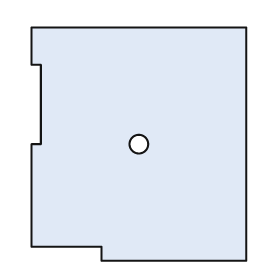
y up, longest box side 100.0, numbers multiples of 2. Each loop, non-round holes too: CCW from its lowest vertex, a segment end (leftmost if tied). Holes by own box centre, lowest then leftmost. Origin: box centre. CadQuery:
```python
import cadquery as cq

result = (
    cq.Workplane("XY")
    .moveTo(-16.0, -50.0)
    .lineTo(46.0, -50.0)
    .lineTo(46.0, 50.0)
    .lineTo(-46.0, 50.0)
    .lineTo(-46.0, 34.0)
    .lineTo(-42.0, 34.0)
    .lineTo(-42.0, 0.0)
    .lineTo(-46.0, 0.0)
    .lineTo(-46.0, -44.0)
    .lineTo(-16.0, -44.0)
    .close()
    .moveTo(0.0, 0.0)
    .circle(4.0)
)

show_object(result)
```